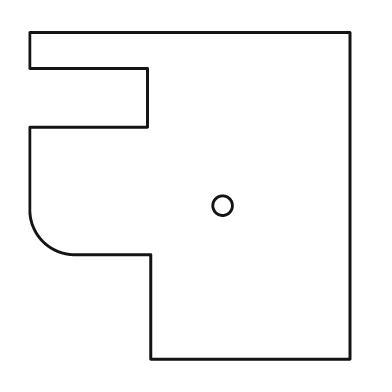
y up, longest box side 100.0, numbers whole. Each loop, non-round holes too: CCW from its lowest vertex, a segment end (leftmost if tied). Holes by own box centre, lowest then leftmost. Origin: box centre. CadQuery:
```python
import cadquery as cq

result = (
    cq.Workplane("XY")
    .moveTo(-12.0, -50.0)
    .lineTo(49.0, -50.0)
    .lineTo(49.0, 50.0)
    .lineTo(-49.0, 50.0)
    .lineTo(-49.0, 39.0)
    .lineTo(-13.0, 39.0)
    .lineTo(-13.0, 21.0)
    .lineTo(-49.0, 21.0)
    .lineTo(-49.0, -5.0)
    .threePointArc((-45.0, -14.0), (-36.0, -18.0))
    .lineTo(-12.0, -18.0)
    .close()
    .moveTo(10.0, -3.0)
    .circle(3.0)
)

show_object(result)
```